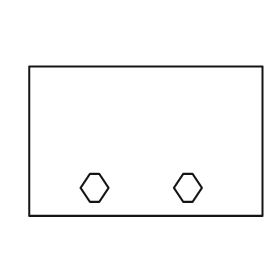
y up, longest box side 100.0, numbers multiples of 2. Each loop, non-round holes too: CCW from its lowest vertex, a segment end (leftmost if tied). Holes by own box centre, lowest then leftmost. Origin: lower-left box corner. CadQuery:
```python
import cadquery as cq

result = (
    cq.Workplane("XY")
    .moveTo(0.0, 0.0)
    .lineTo(100.0, 0.0)
    .lineTo(100.0, 64.0)
    .lineTo(0.0, 64.0)
    .close()
    .moveTo(26.0, 6.0)
    .lineTo(30.0, 6.0)
    .lineTo(34.0, 12.0)
    .lineTo(30.0, 18.0)
    .lineTo(26.0, 18.0)
    .lineTo(22.0, 12.0)
    .close()
    .moveTo(66.0, 6.0)
    .lineTo(70.0, 6.0)
    .lineTo(74.0, 12.0)
    .lineTo(70.0, 18.0)
    .lineTo(66.0, 18.0)
    .lineTo(62.0, 12.0)
    .close()
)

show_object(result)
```